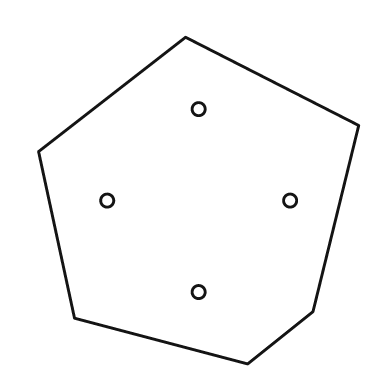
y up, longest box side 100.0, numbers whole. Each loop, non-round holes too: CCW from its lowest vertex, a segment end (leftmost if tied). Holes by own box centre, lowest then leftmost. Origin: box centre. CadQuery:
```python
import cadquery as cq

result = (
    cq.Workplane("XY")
    .moveTo(15.0, -50.0)
    .lineTo(35.0, -34.0)
    .lineTo(49.0, 23.0)
    .lineTo(-4.0, 50.0)
    .lineTo(-49.0, 15.0)
    .lineTo(-38.0, -36.0)
    .close()
    .moveTo(0.0, -28.0)
    .circle(2.0)
    .moveTo(-28.0, 0.0)
    .circle(2.0)
    .moveTo(28.0, 0.0)
    .circle(2.0)
    .moveTo(0.0, 28.0)
    .circle(2.0)
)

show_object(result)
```